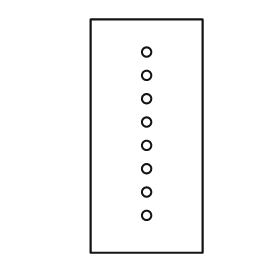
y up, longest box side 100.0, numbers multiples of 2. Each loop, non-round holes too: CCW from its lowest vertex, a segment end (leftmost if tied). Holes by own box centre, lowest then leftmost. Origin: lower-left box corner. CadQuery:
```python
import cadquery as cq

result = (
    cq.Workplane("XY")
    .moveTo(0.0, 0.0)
    .lineTo(48.0, 0.0)
    .lineTo(48.0, 100.0)
    .lineTo(0.0, 100.0)
    .close()
    .moveTo(24.0, 16.0)
    .circle(2.0)
    .moveTo(24.0, 26.0)
    .circle(2.0)
    .moveTo(24.0, 36.0)
    .circle(2.0)
    .moveTo(24.0, 46.0)
    .circle(2.0)
    .moveTo(24.0, 56.0)
    .circle(2.0)
    .moveTo(24.0, 66.0)
    .circle(2.0)
    .moveTo(24.0, 76.0)
    .circle(2.0)
    .moveTo(24.0, 86.0)
    .circle(2.0)
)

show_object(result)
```